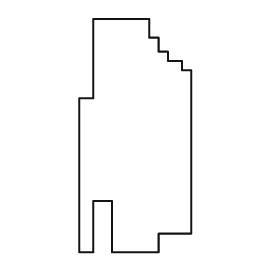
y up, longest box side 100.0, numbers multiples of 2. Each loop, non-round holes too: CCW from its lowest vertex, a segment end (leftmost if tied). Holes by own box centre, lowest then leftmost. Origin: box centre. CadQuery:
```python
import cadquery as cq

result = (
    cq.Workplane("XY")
    .moveTo(-24.0, -50.0)
    .lineTo(-18.0, -50.0)
    .lineTo(-18.0, -28.0)
    .lineTo(-10.0, -28.0)
    .lineTo(-10.0, -50.0)
    .lineTo(10.0, -50.0)
    .lineTo(10.0, -42.0)
    .lineTo(24.0, -42.0)
    .lineTo(24.0, 28.0)
    .lineTo(20.0, 28.0)
    .lineTo(20.0, 32.0)
    .lineTo(14.0, 32.0)
    .lineTo(14.0, 36.0)
    .lineTo(10.0, 36.0)
    .lineTo(10.0, 42.0)
    .lineTo(6.0, 42.0)
    .lineTo(6.0, 50.0)
    .lineTo(-18.0, 50.0)
    .lineTo(-18.0, 16.0)
    .lineTo(-24.0, 16.0)
    .close()
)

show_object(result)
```